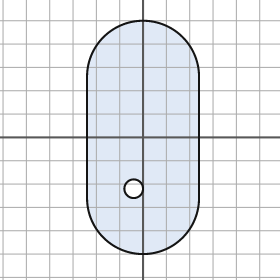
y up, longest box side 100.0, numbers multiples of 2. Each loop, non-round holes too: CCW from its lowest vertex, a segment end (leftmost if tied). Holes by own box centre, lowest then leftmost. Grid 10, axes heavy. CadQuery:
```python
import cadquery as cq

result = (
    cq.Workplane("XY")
    .moveTo(-24.0, -26.0)
    .threePointArc((0.0, -50.0), (24.0, -26.0))
    .lineTo(24.0, 26.0)
    .threePointArc((0.0, 50.0), (-24.0, 26.0))
    .close()
    .moveTo(-4.0, -22.0)
    .circle(4.0)
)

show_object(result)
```